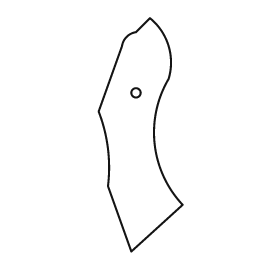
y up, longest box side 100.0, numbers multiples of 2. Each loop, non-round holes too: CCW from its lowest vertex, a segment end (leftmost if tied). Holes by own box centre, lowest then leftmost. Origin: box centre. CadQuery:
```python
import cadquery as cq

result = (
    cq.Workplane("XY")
    .moveTo(-4.0, -50.0)
    .lineTo(18.0, -30.0)
    .threePointArc((6.0, -4.0), (12.0, 24.0))
    .threePointArc((12.0, 38.0), (4.0, 50.0))
    .lineTo(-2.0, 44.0)
    .threePointArc((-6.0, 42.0), (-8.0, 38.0))
    .lineTo(-18.0, 10.0)
    .threePointArc((-14.0, -6.0), (-14.0, -22.0))
    .close()
    .moveTo(-2.0, 18.0)
    .circle(2.0)
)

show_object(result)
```